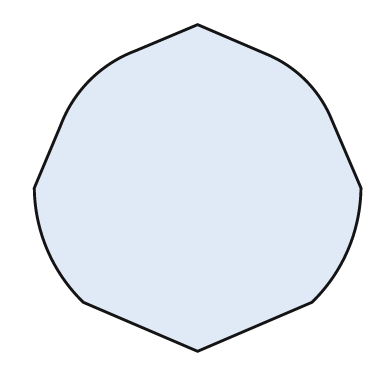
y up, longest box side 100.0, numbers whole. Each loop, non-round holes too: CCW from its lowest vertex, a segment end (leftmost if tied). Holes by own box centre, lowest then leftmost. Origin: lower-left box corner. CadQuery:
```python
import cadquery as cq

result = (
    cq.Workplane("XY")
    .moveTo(50.0, 0.0)
    .lineTo(85.0, 15.0)
    .threePointArc((96.0, 31.0), (100.0, 50.0))
    .lineTo(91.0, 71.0)
    .threePointArc((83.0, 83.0), (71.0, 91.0))
    .lineTo(50.0, 100.0)
    .lineTo(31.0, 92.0)
    .threePointArc((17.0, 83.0), (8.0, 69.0))
    .lineTo(0.0, 50.0)
    .threePointArc((4.0, 31.0), (15.0, 15.0))
    .close()
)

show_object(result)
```